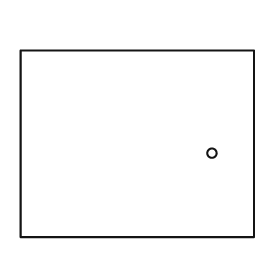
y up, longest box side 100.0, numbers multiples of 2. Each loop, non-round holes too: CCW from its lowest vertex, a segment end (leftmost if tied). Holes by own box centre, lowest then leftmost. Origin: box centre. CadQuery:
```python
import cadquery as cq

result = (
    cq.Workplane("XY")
    .moveTo(-50.0, -40.0)
    .lineTo(50.0, -40.0)
    .lineTo(50.0, 40.0)
    .lineTo(-50.0, 40.0)
    .close()
    .moveTo(32.0, -4.0)
    .circle(2.0)
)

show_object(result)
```